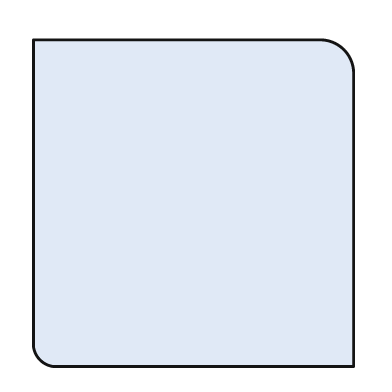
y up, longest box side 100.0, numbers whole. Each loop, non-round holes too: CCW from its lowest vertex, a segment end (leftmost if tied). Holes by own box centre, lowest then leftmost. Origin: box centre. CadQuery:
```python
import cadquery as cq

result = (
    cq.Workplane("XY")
    .moveTo(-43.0, -50.0)
    .lineTo(49.0, -50.0)
    .lineTo(49.0, 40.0)
    .threePointArc((46.0, 47.0), (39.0, 50.0))
    .lineTo(-49.0, 50.0)
    .lineTo(-49.0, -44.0)
    .threePointArc((-47.0, -48.0), (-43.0, -50.0))
    .close()
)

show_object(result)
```